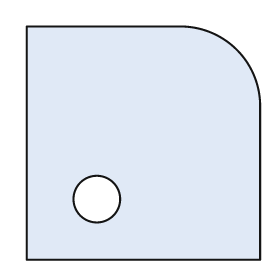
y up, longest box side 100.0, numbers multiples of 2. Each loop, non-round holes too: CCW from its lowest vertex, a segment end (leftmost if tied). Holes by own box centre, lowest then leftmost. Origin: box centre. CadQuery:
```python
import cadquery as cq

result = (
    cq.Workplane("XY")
    .moveTo(-50.0, -50.0)
    .lineTo(50.0, -50.0)
    .lineTo(50.0, 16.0)
    .threePointArc((40.0, 40.0), (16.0, 50.0))
    .lineTo(-50.0, 50.0)
    .close()
    .moveTo(-20.0, -24.0)
    .circle(10.0)
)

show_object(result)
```